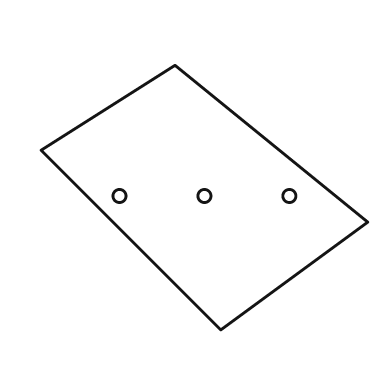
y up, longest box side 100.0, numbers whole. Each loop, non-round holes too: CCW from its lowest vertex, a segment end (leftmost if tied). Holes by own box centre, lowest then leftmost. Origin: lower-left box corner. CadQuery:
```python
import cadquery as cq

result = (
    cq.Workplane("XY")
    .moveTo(55.0, 0.0)
    .lineTo(100.0, 33.0)
    .lineTo(41.0, 81.0)
    .lineTo(0.0, 55.0)
    .close()
    .moveTo(24.0, 41.0)
    .circle(2.0)
    .moveTo(50.0, 41.0)
    .circle(2.0)
    .moveTo(76.0, 41.0)
    .circle(2.0)
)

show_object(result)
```